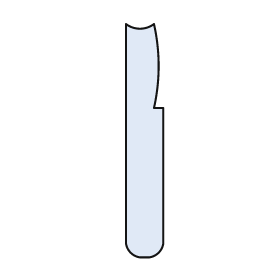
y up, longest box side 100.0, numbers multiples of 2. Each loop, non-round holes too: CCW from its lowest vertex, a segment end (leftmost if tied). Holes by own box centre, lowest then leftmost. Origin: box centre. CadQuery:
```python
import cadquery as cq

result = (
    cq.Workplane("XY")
    .moveTo(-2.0, -50.0)
    .lineTo(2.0, -50.0)
    .threePointArc((6.0, -48.0), (8.0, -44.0))
    .lineTo(8.0, 14.0)
    .lineTo(4.0, 14.0)
    .threePointArc((6.0, 32.0), (4.0, 50.0))
    .threePointArc((-2.0, 48.0), (-8.0, 50.0))
    .lineTo(-8.0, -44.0)
    .threePointArc((-6.0, -48.0), (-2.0, -50.0))
    .close()
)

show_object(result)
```